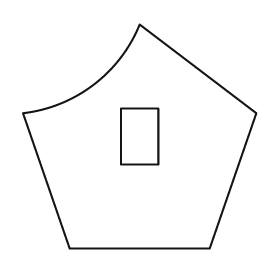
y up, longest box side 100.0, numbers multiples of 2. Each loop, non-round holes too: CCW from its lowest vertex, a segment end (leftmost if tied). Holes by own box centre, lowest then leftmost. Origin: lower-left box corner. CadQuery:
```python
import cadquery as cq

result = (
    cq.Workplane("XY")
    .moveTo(20.0, 0.0)
    .lineTo(80.0, 0.0)
    .lineTo(100.0, 58.0)
    .lineTo(50.0, 96.0)
    .threePointArc((30.0, 70.0), (0.0, 58.0))
    .close()
    .moveTo(42.0, 36.0)
    .lineTo(58.0, 36.0)
    .lineTo(58.0, 60.0)
    .lineTo(42.0, 60.0)
    .close()
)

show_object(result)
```